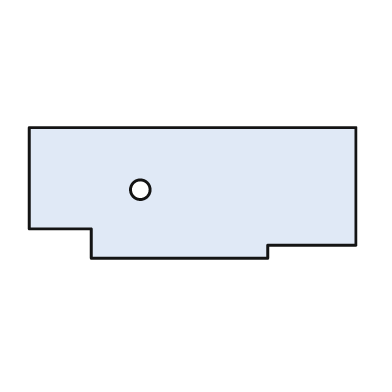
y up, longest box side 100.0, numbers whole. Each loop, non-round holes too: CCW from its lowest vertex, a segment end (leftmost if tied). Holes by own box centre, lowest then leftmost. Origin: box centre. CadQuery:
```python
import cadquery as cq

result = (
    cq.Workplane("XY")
    .moveTo(-31.0, -20.0)
    .lineTo(23.0, -20.0)
    .lineTo(23.0, -16.0)
    .lineTo(50.0, -16.0)
    .lineTo(50.0, 20.0)
    .lineTo(-50.0, 20.0)
    .lineTo(-50.0, -11.0)
    .lineTo(-31.0, -11.0)
    .close()
    .moveTo(-16.0, 1.0)
    .circle(3.0)
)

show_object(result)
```